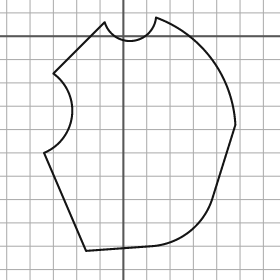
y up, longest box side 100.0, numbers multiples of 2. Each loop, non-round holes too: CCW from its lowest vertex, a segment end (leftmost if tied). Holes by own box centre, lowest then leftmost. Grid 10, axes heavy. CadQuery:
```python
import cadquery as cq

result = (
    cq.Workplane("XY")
    .moveTo(-16.0, -92.0)
    .lineTo(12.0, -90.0)
    .threePointArc((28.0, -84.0), (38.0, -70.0))
    .lineTo(48.0, -38.0)
    .threePointArc((38.0, -10.0), (14.0, 8.0))
    .threePointArc((4.0, -2.0), (-8.0, 6.0))
    .lineTo(-30.0, -16.0)
    .threePointArc((-22.0, -34.0), (-34.0, -50.0))
    .close()
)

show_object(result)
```